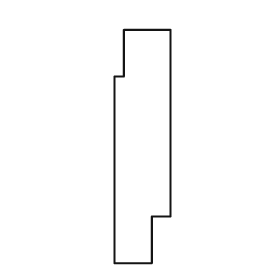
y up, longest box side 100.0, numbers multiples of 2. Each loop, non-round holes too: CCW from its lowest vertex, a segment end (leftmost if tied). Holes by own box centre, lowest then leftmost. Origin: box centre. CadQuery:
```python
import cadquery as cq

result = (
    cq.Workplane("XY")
    .moveTo(-12.0, -50.0)
    .lineTo(4.0, -50.0)
    .lineTo(4.0, -30.0)
    .lineTo(12.0, -30.0)
    .lineTo(12.0, 50.0)
    .lineTo(-8.0, 50.0)
    .lineTo(-8.0, 30.0)
    .lineTo(-12.0, 30.0)
    .close()
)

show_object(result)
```